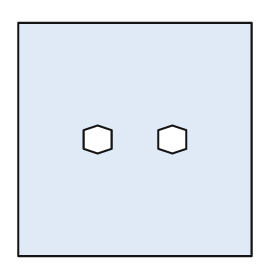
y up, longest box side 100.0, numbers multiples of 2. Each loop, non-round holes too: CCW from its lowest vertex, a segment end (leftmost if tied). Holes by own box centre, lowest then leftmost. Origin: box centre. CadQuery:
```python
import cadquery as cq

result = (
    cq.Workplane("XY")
    .moveTo(-50.0, -50.0)
    .lineTo(50.0, -50.0)
    .lineTo(50.0, 50.0)
    .lineTo(-50.0, 50.0)
    .close()
    .moveTo(-16.0, -6.0)
    .lineTo(-10.0, -4.0)
    .lineTo(-10.0, 4.0)
    .lineTo(-16.0, 6.0)
    .lineTo(-22.0, 4.0)
    .lineTo(-22.0, -4.0)
    .close()
    .moveTo(16.0, -6.0)
    .lineTo(22.0, -4.0)
    .lineTo(22.0, 4.0)
    .lineTo(16.0, 6.0)
    .lineTo(10.0, 4.0)
    .lineTo(10.0, -4.0)
    .close()
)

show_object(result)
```